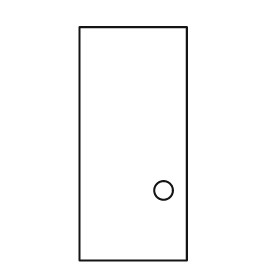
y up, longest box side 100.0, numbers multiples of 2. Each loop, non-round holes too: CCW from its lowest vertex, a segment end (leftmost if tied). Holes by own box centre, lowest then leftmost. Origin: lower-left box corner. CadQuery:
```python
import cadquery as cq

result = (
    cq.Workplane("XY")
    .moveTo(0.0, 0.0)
    .lineTo(46.0, 0.0)
    .lineTo(46.0, 100.0)
    .lineTo(0.0, 100.0)
    .close()
    .moveTo(36.0, 30.0)
    .circle(4.0)
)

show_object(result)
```